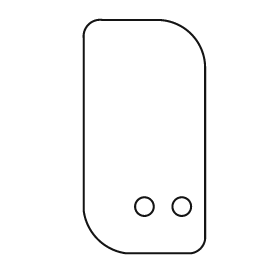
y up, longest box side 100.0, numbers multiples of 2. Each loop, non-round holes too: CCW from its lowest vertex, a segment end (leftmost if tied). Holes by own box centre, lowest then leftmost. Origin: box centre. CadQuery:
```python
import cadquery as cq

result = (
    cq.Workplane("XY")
    .moveTo(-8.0, -50.0)
    .lineTo(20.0, -50.0)
    .threePointArc((24.0, -48.0), (26.0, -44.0))
    .lineTo(26.0, 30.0)
    .threePointArc((20.0, 44.0), (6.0, 50.0))
    .lineTo(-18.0, 50.0)
    .threePointArc((-24.0, 48.0), (-26.0, 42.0))
    .lineTo(-26.0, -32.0)
    .threePointArc((-20.0, -44.0), (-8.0, -50.0))
    .close()
    .moveTo(0.0, -30.0)
    .circle(4.0)
    .moveTo(16.0, -30.0)
    .circle(4.0)
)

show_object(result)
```